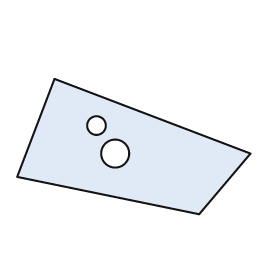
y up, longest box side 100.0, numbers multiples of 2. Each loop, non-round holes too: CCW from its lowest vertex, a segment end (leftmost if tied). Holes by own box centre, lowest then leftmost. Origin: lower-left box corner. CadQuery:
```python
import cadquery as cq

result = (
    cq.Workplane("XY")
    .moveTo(78.0, 0.0)
    .lineTo(100.0, 26.0)
    .lineTo(16.0, 58.0)
    .lineTo(0.0, 16.0)
    .close()
    .moveTo(42.0, 26.0)
    .circle(6.0)
    .moveTo(34.0, 38.0)
    .circle(4.0)
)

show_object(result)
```